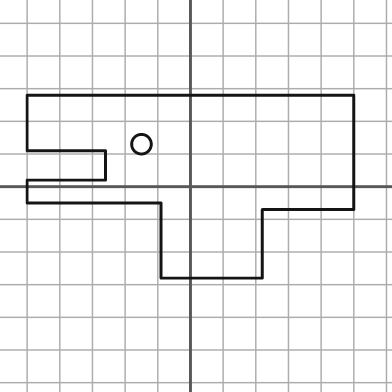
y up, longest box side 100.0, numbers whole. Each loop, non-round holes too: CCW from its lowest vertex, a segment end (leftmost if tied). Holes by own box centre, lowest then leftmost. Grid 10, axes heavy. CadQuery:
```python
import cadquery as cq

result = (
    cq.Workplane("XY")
    .moveTo(-9.0, -28.0)
    .lineTo(22.0, -28.0)
    .lineTo(22.0, -7.0)
    .lineTo(50.0, -7.0)
    .lineTo(50.0, 28.0)
    .lineTo(-50.0, 28.0)
    .lineTo(-50.0, 11.0)
    .lineTo(-26.0, 11.0)
    .lineTo(-26.0, 2.0)
    .lineTo(-50.0, 2.0)
    .lineTo(-50.0, -5.0)
    .lineTo(-9.0, -5.0)
    .close()
    .moveTo(-15.0, 13.0)
    .circle(3.0)
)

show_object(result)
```